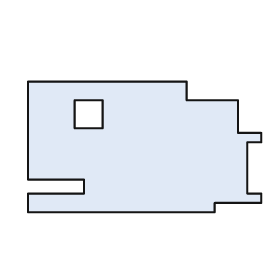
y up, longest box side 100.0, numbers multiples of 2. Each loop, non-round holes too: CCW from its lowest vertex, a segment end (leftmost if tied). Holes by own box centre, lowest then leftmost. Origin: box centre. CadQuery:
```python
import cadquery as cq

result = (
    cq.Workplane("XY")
    .moveTo(-50.0, -28.0)
    .lineTo(30.0, -28.0)
    .lineTo(30.0, -24.0)
    .lineTo(50.0, -24.0)
    .lineTo(50.0, -20.0)
    .lineTo(44.0, -20.0)
    .lineTo(44.0, 2.0)
    .lineTo(50.0, 2.0)
    .lineTo(50.0, 6.0)
    .lineTo(40.0, 6.0)
    .lineTo(40.0, 20.0)
    .lineTo(18.0, 20.0)
    .lineTo(18.0, 28.0)
    .lineTo(-50.0, 28.0)
    .lineTo(-50.0, -14.0)
    .lineTo(-26.0, -14.0)
    .lineTo(-26.0, -20.0)
    .lineTo(-50.0, -20.0)
    .close()
    .moveTo(-30.0, 8.0)
    .lineTo(-18.0, 8.0)
    .lineTo(-18.0, 20.0)
    .lineTo(-30.0, 20.0)
    .close()
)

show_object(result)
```